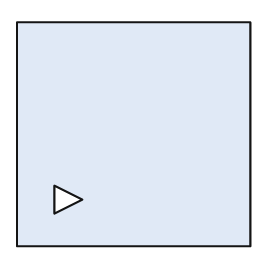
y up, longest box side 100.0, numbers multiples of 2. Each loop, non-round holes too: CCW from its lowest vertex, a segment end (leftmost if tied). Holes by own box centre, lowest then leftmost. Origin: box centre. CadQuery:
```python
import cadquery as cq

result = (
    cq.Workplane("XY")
    .moveTo(-50.0, -48.0)
    .lineTo(50.0, -48.0)
    .lineTo(50.0, 48.0)
    .lineTo(-50.0, 48.0)
    .close()
    .moveTo(-34.0, -34.0)
    .lineTo(-22.0, -28.0)
    .lineTo(-34.0, -22.0)
    .close()
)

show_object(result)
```